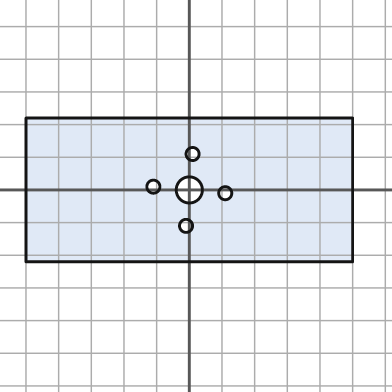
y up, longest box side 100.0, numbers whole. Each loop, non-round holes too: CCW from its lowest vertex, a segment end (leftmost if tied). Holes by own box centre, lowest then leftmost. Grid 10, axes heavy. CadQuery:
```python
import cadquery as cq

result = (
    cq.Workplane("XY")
    .moveTo(-50.0, -22.0)
    .lineTo(50.0, -22.0)
    .lineTo(50.0, 22.0)
    .lineTo(-50.0, 22.0)
    .close()
    .moveTo(-1.0, -11.0)
    .circle(2.0)
    .moveTo(11.0, -1.0)
    .circle(2.0)
    .moveTo(0.0, 0.0)
    .circle(4.0)
    .moveTo(-11.0, 1.0)
    .circle(2.0)
    .moveTo(1.0, 11.0)
    .circle(2.0)
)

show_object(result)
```